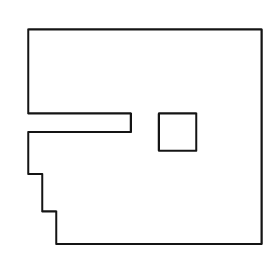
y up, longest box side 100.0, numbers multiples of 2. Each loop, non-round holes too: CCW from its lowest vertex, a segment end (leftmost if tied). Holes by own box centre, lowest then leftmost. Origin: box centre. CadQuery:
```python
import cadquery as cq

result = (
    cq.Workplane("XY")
    .moveTo(-38.0, -46.0)
    .lineTo(50.0, -46.0)
    .lineTo(50.0, 46.0)
    .lineTo(-50.0, 46.0)
    .lineTo(-50.0, 10.0)
    .lineTo(-6.0, 10.0)
    .lineTo(-6.0, 2.0)
    .lineTo(-50.0, 2.0)
    .lineTo(-50.0, -16.0)
    .lineTo(-44.0, -16.0)
    .lineTo(-44.0, -32.0)
    .lineTo(-38.0, -32.0)
    .close()
    .moveTo(6.0, -6.0)
    .lineTo(22.0, -6.0)
    .lineTo(22.0, 10.0)
    .lineTo(6.0, 10.0)
    .close()
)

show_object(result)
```